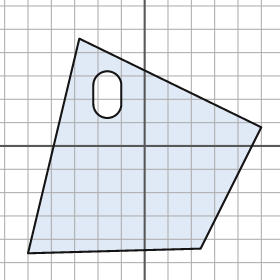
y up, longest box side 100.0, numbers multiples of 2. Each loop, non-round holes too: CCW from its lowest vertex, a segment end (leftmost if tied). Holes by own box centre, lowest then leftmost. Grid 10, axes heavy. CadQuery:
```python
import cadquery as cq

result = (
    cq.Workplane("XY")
    .moveTo(-50.0, -46.0)
    .lineTo(24.0, -44.0)
    .lineTo(50.0, 8.0)
    .lineTo(-28.0, 46.0)
    .close()
    .moveTo(-22.0, 18.0)
    .threePointArc((-16.0, 12.0), (-10.0, 18.0))
    .lineTo(-10.0, 26.0)
    .threePointArc((-16.0, 32.0), (-22.0, 26.0))
    .close()
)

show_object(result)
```